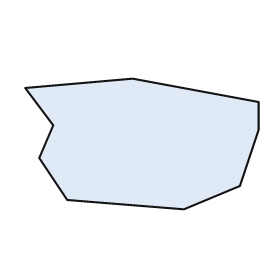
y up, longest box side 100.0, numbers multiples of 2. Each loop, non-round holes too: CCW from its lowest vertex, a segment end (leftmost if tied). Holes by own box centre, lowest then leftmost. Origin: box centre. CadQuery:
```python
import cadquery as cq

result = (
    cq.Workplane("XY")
    .moveTo(18.0, -28.0)
    .lineTo(42.0, -18.0)
    .lineTo(50.0, 6.0)
    .lineTo(50.0, 18.0)
    .lineTo(-4.0, 28.0)
    .lineTo(-50.0, 24.0)
    .lineTo(-38.0, 8.0)
    .lineTo(-44.0, -6.0)
    .lineTo(-32.0, -24.0)
    .close()
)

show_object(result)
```